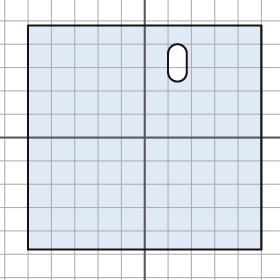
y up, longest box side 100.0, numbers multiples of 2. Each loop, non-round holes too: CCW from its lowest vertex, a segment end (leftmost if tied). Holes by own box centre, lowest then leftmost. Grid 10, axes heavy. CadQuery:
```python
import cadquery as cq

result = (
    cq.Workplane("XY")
    .moveTo(-50.0, -48.0)
    .lineTo(50.0, -48.0)
    .lineTo(50.0, 48.0)
    .lineTo(-50.0, 48.0)
    .close()
    .moveTo(10.0, 28.0)
    .threePointArc((14.0, 24.0), (18.0, 28.0))
    .lineTo(18.0, 36.0)
    .threePointArc((14.0, 40.0), (10.0, 36.0))
    .close()
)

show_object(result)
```